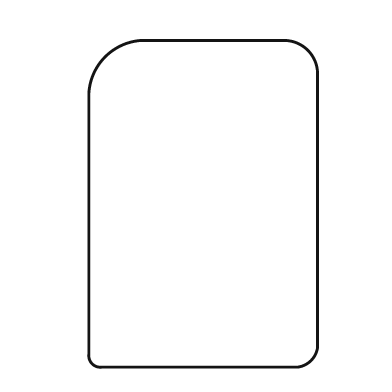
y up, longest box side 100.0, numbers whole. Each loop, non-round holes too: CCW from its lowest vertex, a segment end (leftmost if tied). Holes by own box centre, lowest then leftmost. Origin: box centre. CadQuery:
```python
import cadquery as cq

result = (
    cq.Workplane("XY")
    .moveTo(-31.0, -50.0)
    .lineTo(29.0, -50.0)
    .threePointArc((33.0, -48.0), (35.0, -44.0))
    .lineTo(35.0, 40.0)
    .threePointArc((32.0, 47.0), (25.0, 50.0))
    .lineTo(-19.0, 50.0)
    .threePointArc((-30.0, 45.0), (-35.0, 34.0))
    .lineTo(-35.0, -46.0)
    .threePointArc((-34.0, -49.0), (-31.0, -50.0))
    .close()
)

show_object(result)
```